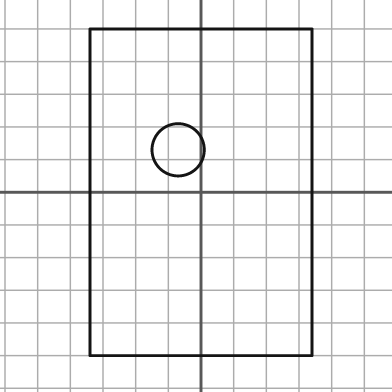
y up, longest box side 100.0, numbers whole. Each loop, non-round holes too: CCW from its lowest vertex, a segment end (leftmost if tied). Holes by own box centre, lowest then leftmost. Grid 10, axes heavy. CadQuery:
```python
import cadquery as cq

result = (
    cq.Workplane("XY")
    .moveTo(-34.0, -50.0)
    .lineTo(34.0, -50.0)
    .lineTo(34.0, 50.0)
    .lineTo(-34.0, 50.0)
    .close()
    .moveTo(-7.0, 13.0)
    .circle(8.0)
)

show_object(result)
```